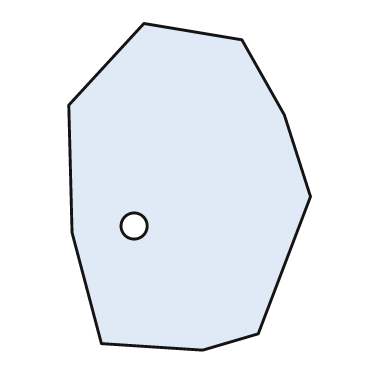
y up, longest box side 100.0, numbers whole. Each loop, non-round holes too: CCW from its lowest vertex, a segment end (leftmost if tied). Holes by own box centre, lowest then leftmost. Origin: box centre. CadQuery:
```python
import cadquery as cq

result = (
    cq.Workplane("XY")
    .moveTo(4.0, -50.0)
    .lineTo(21.0, -45.0)
    .lineTo(37.0, -3.0)
    .lineTo(29.0, 22.0)
    .lineTo(16.0, 45.0)
    .lineTo(-14.0, 50.0)
    .lineTo(-37.0, 25.0)
    .lineTo(-36.0, -14.0)
    .lineTo(-27.0, -48.0)
    .close()
    .moveTo(-17.0, -12.0)
    .circle(4.0)
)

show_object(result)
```